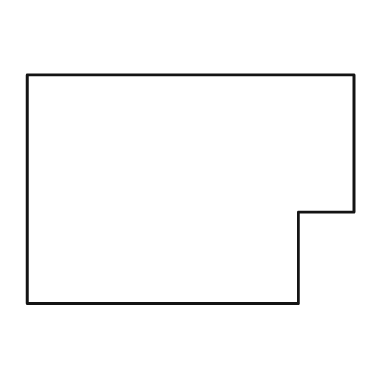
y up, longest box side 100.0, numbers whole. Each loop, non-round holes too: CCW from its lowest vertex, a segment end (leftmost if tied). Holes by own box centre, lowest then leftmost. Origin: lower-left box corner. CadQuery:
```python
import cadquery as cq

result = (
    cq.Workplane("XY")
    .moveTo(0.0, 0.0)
    .lineTo(83.0, 0.0)
    .lineTo(83.0, 28.0)
    .lineTo(100.0, 28.0)
    .lineTo(100.0, 70.0)
    .lineTo(0.0, 70.0)
    .close()
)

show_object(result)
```